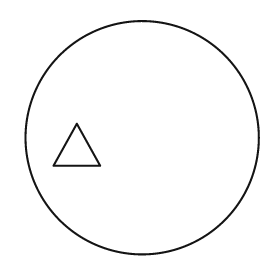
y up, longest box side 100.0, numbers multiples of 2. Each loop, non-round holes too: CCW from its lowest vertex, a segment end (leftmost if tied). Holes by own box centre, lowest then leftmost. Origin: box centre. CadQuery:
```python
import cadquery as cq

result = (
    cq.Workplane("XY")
    .moveTo(0.0, 0.0)
    .circle(50.0)
    .moveTo(-38.0, -12.0)
    .lineTo(-18.0, -12.0)
    .lineTo(-28.0, 6.0)
    .close()
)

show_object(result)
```